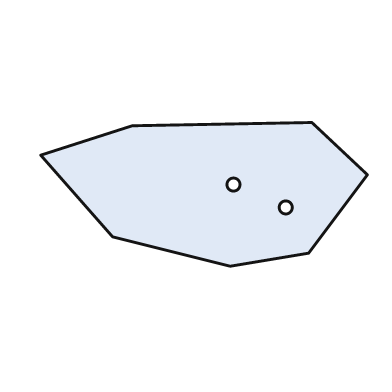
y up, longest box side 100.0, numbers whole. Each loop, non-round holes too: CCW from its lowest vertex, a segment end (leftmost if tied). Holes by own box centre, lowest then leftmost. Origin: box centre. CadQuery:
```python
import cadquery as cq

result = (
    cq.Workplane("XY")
    .moveTo(8.0, -22.0)
    .lineTo(32.0, -18.0)
    .lineTo(50.0, 6.0)
    .lineTo(33.0, 22.0)
    .lineTo(-22.0, 21.0)
    .lineTo(-50.0, 12.0)
    .lineTo(-28.0, -13.0)
    .close()
    .moveTo(25.0, -4.0)
    .circle(2.0)
    .moveTo(9.0, 3.0)
    .circle(2.0)
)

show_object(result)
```